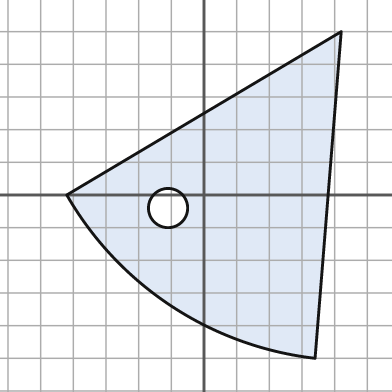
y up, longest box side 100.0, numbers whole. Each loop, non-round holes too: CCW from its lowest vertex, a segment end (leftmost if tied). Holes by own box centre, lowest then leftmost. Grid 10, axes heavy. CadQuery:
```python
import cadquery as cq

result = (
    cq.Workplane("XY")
    .moveTo(34.0, -50.0)
    .lineTo(42.0, 50.0)
    .lineTo(-42.0, 0.0)
    .threePointArc((-10.0, -34.0), (34.0, -50.0))
    .close()
    .moveTo(-11.0, -4.0)
    .circle(6.0)
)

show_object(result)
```